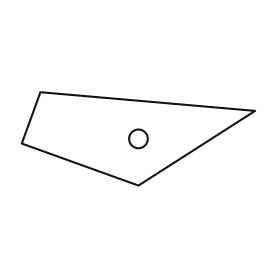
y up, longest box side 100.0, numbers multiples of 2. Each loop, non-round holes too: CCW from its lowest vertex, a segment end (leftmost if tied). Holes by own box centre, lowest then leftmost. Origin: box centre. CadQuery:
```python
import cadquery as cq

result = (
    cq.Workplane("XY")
    .moveTo(0.0, -20.0)
    .lineTo(50.0, 12.0)
    .lineTo(-42.0, 20.0)
    .lineTo(-50.0, -2.0)
    .close()
    .moveTo(0.0, 0.0)
    .circle(4.0)
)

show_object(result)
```